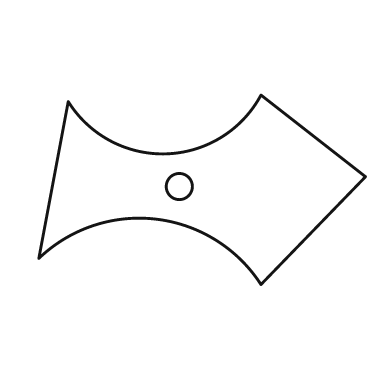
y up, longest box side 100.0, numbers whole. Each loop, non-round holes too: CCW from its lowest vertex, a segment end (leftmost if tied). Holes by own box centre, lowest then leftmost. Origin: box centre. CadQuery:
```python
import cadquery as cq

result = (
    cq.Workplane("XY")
    .moveTo(18.0, -29.0)
    .lineTo(50.0, 4.0)
    .lineTo(18.0, 29.0)
    .threePointArc((-11.0, 11.0), (-41.0, 27.0))
    .lineTo(-50.0, -21.0)
    .threePointArc((-14.0, -9.0), (18.0, -29.0))
    .close()
    .moveTo(-7.0, 1.0)
    .circle(4.0)
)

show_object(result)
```